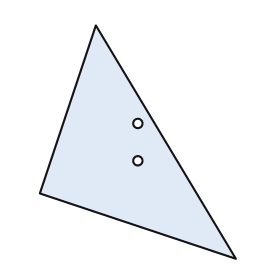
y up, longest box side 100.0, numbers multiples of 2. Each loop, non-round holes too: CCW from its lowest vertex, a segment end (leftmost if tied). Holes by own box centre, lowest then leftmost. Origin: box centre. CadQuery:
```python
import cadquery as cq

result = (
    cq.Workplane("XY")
    .moveTo(42.0, -50.0)
    .lineTo(-18.0, 50.0)
    .lineTo(-42.0, -22.0)
    .close()
    .moveTo(0.0, -8.0)
    .circle(2.0)
    .moveTo(0.0, 8.0)
    .circle(2.0)
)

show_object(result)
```